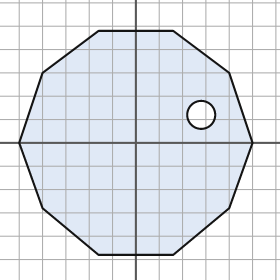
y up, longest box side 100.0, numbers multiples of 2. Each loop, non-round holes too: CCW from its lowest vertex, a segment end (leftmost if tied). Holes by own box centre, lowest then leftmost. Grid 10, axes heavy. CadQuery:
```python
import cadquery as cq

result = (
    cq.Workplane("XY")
    .moveTo(-16.0, -48.0)
    .lineTo(16.0, -48.0)
    .lineTo(40.0, -28.0)
    .lineTo(50.0, 0.0)
    .lineTo(40.0, 30.0)
    .lineTo(16.0, 48.0)
    .lineTo(-16.0, 48.0)
    .lineTo(-40.0, 30.0)
    .lineTo(-50.0, 0.0)
    .lineTo(-40.0, -28.0)
    .close()
    .moveTo(28.0, 12.0)
    .circle(6.0)
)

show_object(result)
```